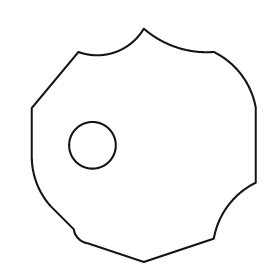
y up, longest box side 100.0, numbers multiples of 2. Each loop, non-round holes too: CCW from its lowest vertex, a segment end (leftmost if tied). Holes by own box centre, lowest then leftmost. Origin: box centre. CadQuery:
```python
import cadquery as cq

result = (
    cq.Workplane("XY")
    .moveTo(0.0, -50.0)
    .lineTo(30.0, -40.0)
    .threePointArc((36.0, -26.0), (48.0, -16.0))
    .lineTo(48.0, 16.0)
    .threePointArc((42.0, 30.0), (30.0, 40.0))
    .threePointArc((14.0, 42.0), (0.0, 50.0))
    .threePointArc((-12.0, 40.0), (-28.0, 40.0))
    .lineTo(-48.0, 16.0)
    .lineTo(-48.0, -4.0)
    .threePointArc((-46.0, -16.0), (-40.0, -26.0))
    .lineTo(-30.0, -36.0)
    .threePointArc((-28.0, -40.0), (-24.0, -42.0))
    .close()
    .moveTo(-22.0, 0.0)
    .circle(10.0)
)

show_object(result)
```